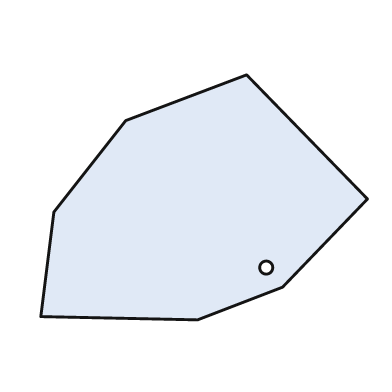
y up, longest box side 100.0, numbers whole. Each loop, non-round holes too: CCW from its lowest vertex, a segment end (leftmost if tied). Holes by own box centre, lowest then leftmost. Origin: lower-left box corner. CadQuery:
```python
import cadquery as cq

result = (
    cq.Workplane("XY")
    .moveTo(48.0, 0.0)
    .lineTo(74.0, 10.0)
    .lineTo(100.0, 37.0)
    .lineTo(63.0, 75.0)
    .lineTo(26.0, 61.0)
    .lineTo(4.0, 33.0)
    .lineTo(0.0, 1.0)
    .close()
    .moveTo(69.0, 16.0)
    .circle(2.0)
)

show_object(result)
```